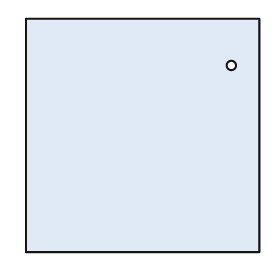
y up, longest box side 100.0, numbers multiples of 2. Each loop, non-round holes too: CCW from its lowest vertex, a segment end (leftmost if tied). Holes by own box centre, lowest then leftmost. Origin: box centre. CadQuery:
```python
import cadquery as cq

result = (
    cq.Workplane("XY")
    .moveTo(-50.0, -50.0)
    .lineTo(50.0, -50.0)
    .lineTo(50.0, 50.0)
    .lineTo(-50.0, 50.0)
    .close()
    .moveTo(38.0, 30.0)
    .circle(2.0)
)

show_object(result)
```